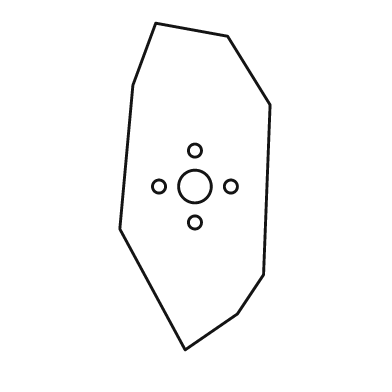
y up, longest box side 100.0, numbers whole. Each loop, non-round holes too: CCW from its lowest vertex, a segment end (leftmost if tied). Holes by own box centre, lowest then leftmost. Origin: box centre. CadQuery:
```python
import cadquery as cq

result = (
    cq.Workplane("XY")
    .moveTo(-3.0, -50.0)
    .lineTo(13.0, -39.0)
    .lineTo(21.0, -27.0)
    .lineTo(23.0, 25.0)
    .lineTo(10.0, 46.0)
    .lineTo(-12.0, 50.0)
    .lineTo(-19.0, 31.0)
    .lineTo(-23.0, -13.0)
    .close()
    .moveTo(0.0, -11.0)
    .circle(2.0)
    .moveTo(-11.0, 0.0)
    .circle(2.0)
    .moveTo(0.0, 0.0)
    .circle(5.0)
    .moveTo(11.0, 0.0)
    .circle(2.0)
    .moveTo(0.0, 11.0)
    .circle(2.0)
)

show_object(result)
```